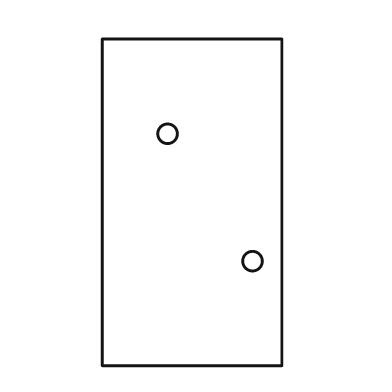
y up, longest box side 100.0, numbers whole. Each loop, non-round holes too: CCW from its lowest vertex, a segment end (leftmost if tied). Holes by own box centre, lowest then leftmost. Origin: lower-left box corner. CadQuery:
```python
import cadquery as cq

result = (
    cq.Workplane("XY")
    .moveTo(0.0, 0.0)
    .lineTo(55.0, 0.0)
    .lineTo(55.0, 100.0)
    .lineTo(0.0, 100.0)
    .close()
    .moveTo(46.0, 32.0)
    .circle(3.0)
    .moveTo(20.0, 71.0)
    .circle(3.0)
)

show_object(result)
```